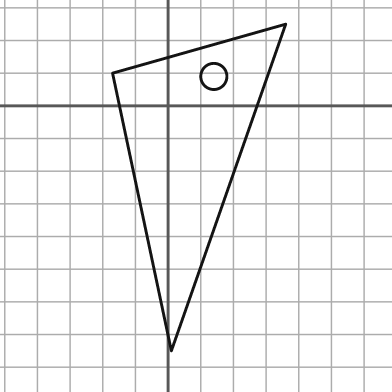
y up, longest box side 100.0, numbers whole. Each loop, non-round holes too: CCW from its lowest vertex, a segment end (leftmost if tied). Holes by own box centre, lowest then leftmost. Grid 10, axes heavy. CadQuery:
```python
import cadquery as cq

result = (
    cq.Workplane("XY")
    .moveTo(1.0, -75.0)
    .lineTo(36.0, 25.0)
    .lineTo(-17.0, 10.0)
    .close()
    .moveTo(14.0, 9.0)
    .circle(4.0)
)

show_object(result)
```